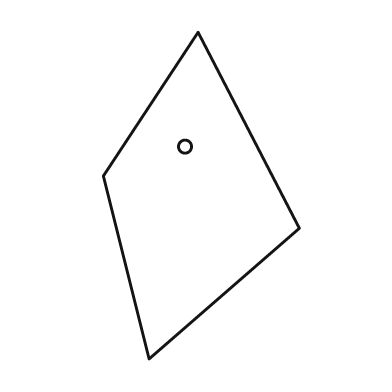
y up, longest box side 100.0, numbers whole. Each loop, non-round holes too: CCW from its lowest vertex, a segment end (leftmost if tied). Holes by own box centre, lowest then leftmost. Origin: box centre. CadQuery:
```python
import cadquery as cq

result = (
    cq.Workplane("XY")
    .moveTo(-16.0, -50.0)
    .lineTo(30.0, -10.0)
    .lineTo(-1.0, 50.0)
    .lineTo(-30.0, 6.0)
    .close()
    .moveTo(-5.0, 15.0)
    .circle(2.0)
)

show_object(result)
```